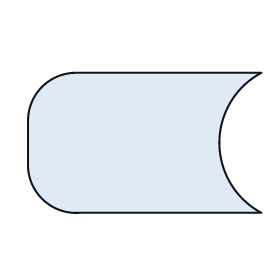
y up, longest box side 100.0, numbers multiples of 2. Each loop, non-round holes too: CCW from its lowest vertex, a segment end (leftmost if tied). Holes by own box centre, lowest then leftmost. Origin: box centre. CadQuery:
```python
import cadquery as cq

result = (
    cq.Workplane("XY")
    .moveTo(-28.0, -30.0)
    .lineTo(50.0, -30.0)
    .threePointArc((32.0, 0.0), (50.0, 30.0))
    .lineTo(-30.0, 30.0)
    .threePointArc((-44.0, 24.0), (-50.0, 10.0))
    .lineTo(-50.0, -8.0)
    .threePointArc((-44.0, -24.0), (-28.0, -30.0))
    .close()
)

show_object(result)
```